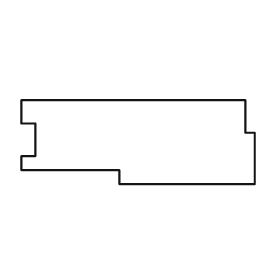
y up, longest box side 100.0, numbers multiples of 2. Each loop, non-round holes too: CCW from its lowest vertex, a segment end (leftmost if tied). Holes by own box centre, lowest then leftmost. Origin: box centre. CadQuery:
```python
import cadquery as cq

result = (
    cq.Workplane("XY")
    .moveTo(-8.0, -18.0)
    .lineTo(50.0, -18.0)
    .lineTo(50.0, 4.0)
    .lineTo(46.0, 4.0)
    .lineTo(46.0, 18.0)
    .lineTo(-50.0, 18.0)
    .lineTo(-50.0, 8.0)
    .lineTo(-44.0, 8.0)
    .lineTo(-44.0, -6.0)
    .lineTo(-50.0, -6.0)
    .lineTo(-50.0, -12.0)
    .lineTo(-8.0, -12.0)
    .close()
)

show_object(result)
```